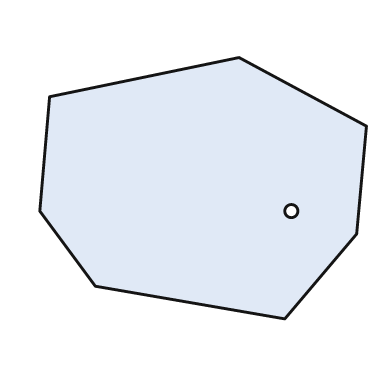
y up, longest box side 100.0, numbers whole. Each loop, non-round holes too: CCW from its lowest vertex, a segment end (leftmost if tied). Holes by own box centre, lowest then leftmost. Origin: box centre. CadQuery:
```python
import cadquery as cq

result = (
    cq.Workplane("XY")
    .moveTo(25.0, -40.0)
    .lineTo(47.0, -14.0)
    .lineTo(50.0, 19.0)
    .lineTo(11.0, 40.0)
    .lineTo(-47.0, 28.0)
    .lineTo(-50.0, -7.0)
    .lineTo(-33.0, -30.0)
    .close()
    .moveTo(27.0, -7.0)
    .circle(2.0)
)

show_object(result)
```